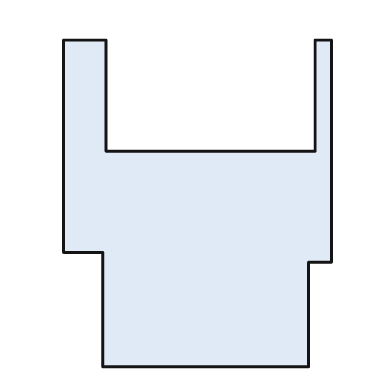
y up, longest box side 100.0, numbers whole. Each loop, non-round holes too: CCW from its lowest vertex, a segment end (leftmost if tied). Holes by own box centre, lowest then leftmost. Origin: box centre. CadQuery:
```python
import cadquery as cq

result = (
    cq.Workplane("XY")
    .moveTo(-29.0, -50.0)
    .lineTo(34.0, -50.0)
    .lineTo(34.0, -18.0)
    .lineTo(41.0, -18.0)
    .lineTo(41.0, 50.0)
    .lineTo(36.0, 50.0)
    .lineTo(36.0, 16.0)
    .lineTo(-28.0, 16.0)
    .lineTo(-28.0, 50.0)
    .lineTo(-41.0, 50.0)
    .lineTo(-41.0, -15.0)
    .lineTo(-29.0, -15.0)
    .close()
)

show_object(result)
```